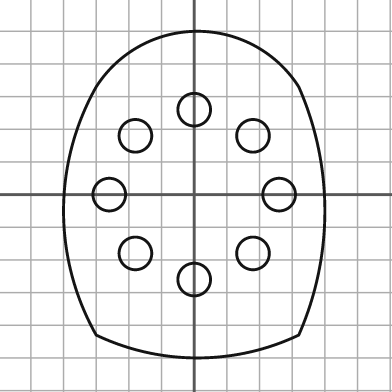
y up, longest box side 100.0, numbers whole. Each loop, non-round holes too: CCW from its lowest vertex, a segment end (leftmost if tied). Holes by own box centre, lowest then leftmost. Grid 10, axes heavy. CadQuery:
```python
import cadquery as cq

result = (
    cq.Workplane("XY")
    .moveTo(-30.0, -43.0)
    .threePointArc((1.0, -50.0), (32.0, -43.0))
    .threePointArc((40.0, -5.0), (32.0, 33.0))
    .threePointArc((1.0, 50.0), (-30.0, 33.0))
    .threePointArc((-40.0, -5.0), (-30.0, -43.0))
    .close()
    .moveTo(0.0, -26.0)
    .circle(5.0)
    .moveTo(-18.0, -18.0)
    .circle(5.0)
    .moveTo(18.0, -18.0)
    .circle(5.0)
    .moveTo(-26.0, 0.0)
    .circle(5.0)
    .moveTo(26.0, 0.0)
    .circle(5.0)
    .moveTo(-18.0, 18.0)
    .circle(5.0)
    .moveTo(18.0, 18.0)
    .circle(5.0)
    .moveTo(0.0, 26.0)
    .circle(5.0)
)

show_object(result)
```